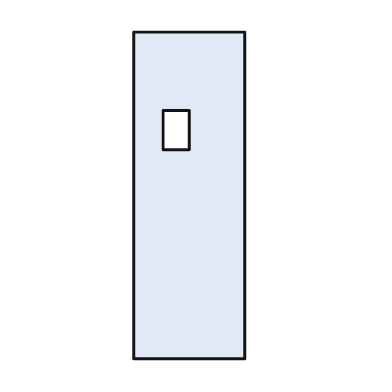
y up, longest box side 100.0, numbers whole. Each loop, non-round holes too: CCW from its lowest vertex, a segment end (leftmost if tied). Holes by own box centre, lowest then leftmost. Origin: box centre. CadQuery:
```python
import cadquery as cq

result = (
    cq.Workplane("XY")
    .moveTo(-17.0, -50.0)
    .lineTo(17.0, -50.0)
    .lineTo(17.0, 50.0)
    .lineTo(-17.0, 50.0)
    .close()
    .moveTo(-8.0, 14.0)
    .lineTo(0.0, 14.0)
    .lineTo(0.0, 26.0)
    .lineTo(-8.0, 26.0)
    .close()
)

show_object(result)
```